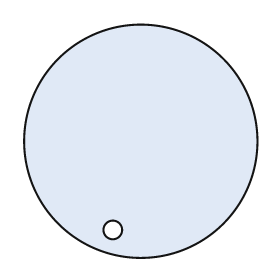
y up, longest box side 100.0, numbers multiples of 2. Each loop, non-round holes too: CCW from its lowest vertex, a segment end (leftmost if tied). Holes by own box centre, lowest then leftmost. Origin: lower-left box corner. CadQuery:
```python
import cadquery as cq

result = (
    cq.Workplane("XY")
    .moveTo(50.0, 50.0)
    .circle(50.0)
    .moveTo(38.0, 12.0)
    .circle(4.0)
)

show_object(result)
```